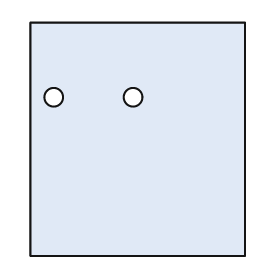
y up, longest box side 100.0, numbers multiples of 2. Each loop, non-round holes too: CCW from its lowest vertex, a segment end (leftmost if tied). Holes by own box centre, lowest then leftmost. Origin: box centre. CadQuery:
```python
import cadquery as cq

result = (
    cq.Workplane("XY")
    .moveTo(-46.0, -50.0)
    .lineTo(46.0, -50.0)
    .lineTo(46.0, 50.0)
    .lineTo(-46.0, 50.0)
    .close()
    .moveTo(-36.0, 18.0)
    .circle(4.0)
    .moveTo(-2.0, 18.0)
    .circle(4.0)
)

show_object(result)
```